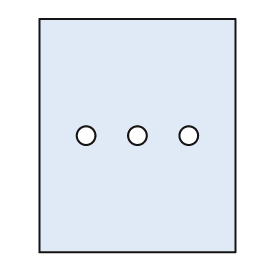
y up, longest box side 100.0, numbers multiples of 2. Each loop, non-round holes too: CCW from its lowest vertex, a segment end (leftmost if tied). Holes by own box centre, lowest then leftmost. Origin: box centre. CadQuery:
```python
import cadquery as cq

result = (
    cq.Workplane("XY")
    .moveTo(-42.0, -50.0)
    .lineTo(42.0, -50.0)
    .lineTo(42.0, 50.0)
    .lineTo(-42.0, 50.0)
    .close()
    .moveTo(-22.0, 0.0)
    .circle(4.0)
    .moveTo(0.0, 0.0)
    .circle(4.0)
    .moveTo(22.0, 0.0)
    .circle(4.0)
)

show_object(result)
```